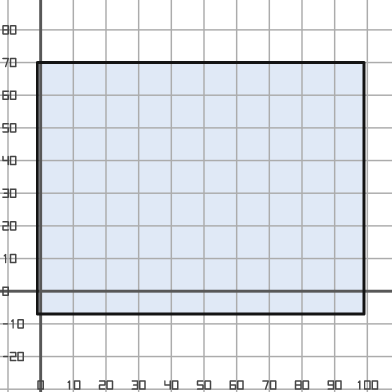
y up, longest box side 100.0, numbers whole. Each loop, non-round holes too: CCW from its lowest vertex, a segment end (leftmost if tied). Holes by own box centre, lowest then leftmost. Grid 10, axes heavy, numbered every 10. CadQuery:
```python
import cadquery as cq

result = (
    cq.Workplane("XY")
    .moveTo(-1.0, -7.0)
    .lineTo(99.0, -7.0)
    .lineTo(99.0, 70.0)
    .lineTo(-1.0, 70.0)
    .close()
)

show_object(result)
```